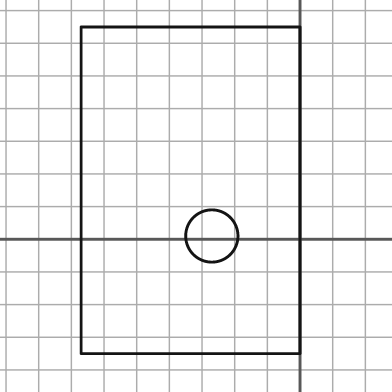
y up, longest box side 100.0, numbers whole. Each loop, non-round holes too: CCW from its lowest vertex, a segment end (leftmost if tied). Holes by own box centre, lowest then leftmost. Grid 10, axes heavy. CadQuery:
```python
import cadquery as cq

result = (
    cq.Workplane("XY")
    .moveTo(-67.0, -35.0)
    .lineTo(0.0, -35.0)
    .lineTo(0.0, 65.0)
    .lineTo(-67.0, 65.0)
    .close()
    .moveTo(-27.0, 1.0)
    .circle(8.0)
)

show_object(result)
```